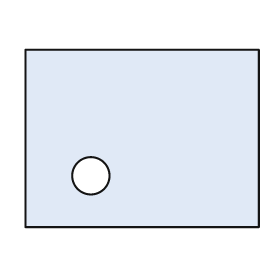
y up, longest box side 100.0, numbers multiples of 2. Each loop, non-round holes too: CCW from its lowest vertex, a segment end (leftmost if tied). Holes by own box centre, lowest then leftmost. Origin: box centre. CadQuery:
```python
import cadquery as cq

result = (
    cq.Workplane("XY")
    .moveTo(-50.0, -38.0)
    .lineTo(50.0, -38.0)
    .lineTo(50.0, 38.0)
    .lineTo(-50.0, 38.0)
    .close()
    .moveTo(-22.0, -16.0)
    .circle(8.0)
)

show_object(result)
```